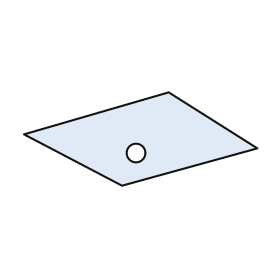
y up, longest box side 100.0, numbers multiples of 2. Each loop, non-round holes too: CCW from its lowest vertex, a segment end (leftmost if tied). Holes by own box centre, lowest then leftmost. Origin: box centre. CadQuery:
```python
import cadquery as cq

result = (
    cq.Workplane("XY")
    .moveTo(-8.0, -20.0)
    .lineTo(50.0, -4.0)
    .lineTo(12.0, 20.0)
    .lineTo(-50.0, 2.0)
    .close()
    .moveTo(-2.0, -6.0)
    .circle(4.0)
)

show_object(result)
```